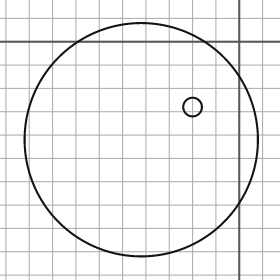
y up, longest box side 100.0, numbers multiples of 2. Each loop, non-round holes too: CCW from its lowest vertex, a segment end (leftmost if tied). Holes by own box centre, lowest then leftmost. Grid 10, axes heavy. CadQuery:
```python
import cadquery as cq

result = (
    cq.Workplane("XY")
    .moveTo(-42.0, -42.0)
    .circle(50.0)
    .moveTo(-20.0, -28.0)
    .circle(4.0)
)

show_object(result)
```